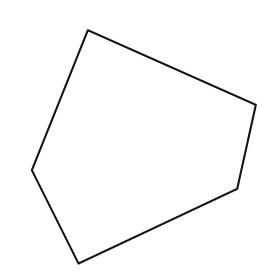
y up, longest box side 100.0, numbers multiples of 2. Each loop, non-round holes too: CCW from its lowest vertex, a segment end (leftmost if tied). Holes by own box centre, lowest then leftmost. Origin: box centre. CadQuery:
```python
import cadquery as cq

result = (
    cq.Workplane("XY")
    .moveTo(-28.0, -50.0)
    .lineTo(40.0, -18.0)
    .lineTo(48.0, 18.0)
    .lineTo(-24.0, 50.0)
    .lineTo(-48.0, -10.0)
    .close()
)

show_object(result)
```